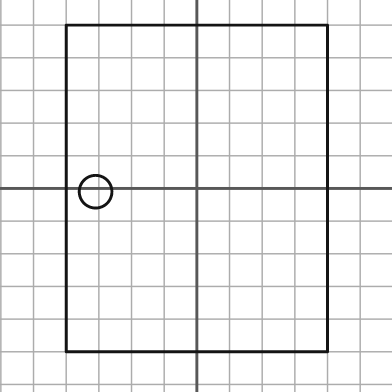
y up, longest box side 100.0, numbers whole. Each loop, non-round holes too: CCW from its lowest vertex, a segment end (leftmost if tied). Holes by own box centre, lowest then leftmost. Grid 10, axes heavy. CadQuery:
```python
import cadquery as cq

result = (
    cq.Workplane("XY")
    .moveTo(-40.0, -50.0)
    .lineTo(40.0, -50.0)
    .lineTo(40.0, 50.0)
    .lineTo(-40.0, 50.0)
    .close()
    .moveTo(-31.0, -1.0)
    .circle(5.0)
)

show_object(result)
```